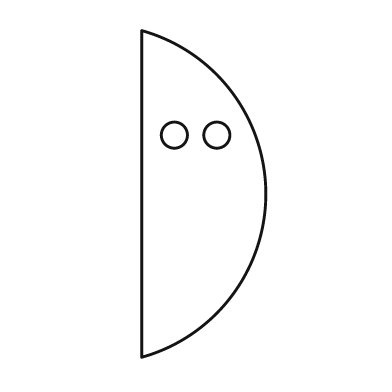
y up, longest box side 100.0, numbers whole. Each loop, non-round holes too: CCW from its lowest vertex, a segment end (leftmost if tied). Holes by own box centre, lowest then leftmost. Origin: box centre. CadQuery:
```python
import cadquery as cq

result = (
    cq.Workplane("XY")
    .moveTo(-19.0, -50.0)
    .threePointArc((19.0, 0.0), (-19.0, 50.0))
    .close()
    .moveTo(-9.0, 18.0)
    .circle(4.0)
    .moveTo(4.0, 18.0)
    .circle(4.0)
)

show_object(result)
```